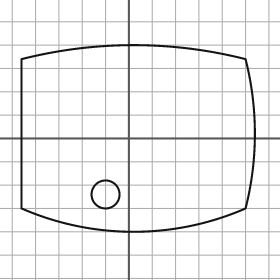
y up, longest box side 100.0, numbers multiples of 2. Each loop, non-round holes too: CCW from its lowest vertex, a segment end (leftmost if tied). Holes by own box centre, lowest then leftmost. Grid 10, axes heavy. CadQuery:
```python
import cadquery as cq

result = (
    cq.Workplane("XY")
    .moveTo(-46.0, -30.0)
    .threePointArc((2.0, -40.0), (50.0, -30.0))
    .threePointArc((54.0, 2.0), (50.0, 34.0))
    .threePointArc((2.0, 40.0), (-46.0, 34.0))
    .close()
    .moveTo(-10.0, -24.0)
    .circle(6.0)
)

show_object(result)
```